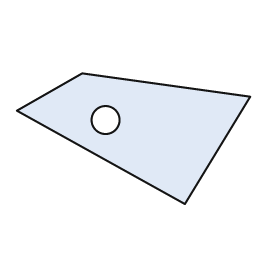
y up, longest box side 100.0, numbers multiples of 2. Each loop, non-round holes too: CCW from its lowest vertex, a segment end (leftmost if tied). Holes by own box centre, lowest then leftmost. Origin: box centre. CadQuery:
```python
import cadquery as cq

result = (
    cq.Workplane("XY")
    .moveTo(22.0, -28.0)
    .lineTo(50.0, 18.0)
    .lineTo(-22.0, 28.0)
    .lineTo(-50.0, 12.0)
    .close()
    .moveTo(-12.0, 8.0)
    .circle(6.0)
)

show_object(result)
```